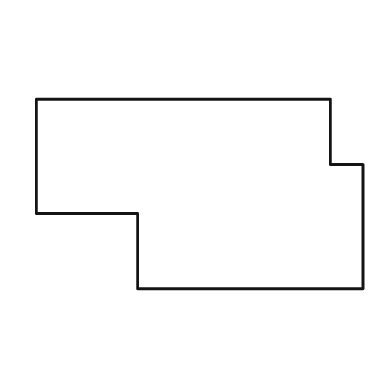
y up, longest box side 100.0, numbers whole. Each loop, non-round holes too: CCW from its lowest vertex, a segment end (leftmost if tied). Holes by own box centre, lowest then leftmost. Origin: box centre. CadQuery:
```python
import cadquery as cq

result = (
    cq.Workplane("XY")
    .moveTo(-19.0, -29.0)
    .lineTo(50.0, -29.0)
    .lineTo(50.0, 9.0)
    .lineTo(40.0, 9.0)
    .lineTo(40.0, 29.0)
    .lineTo(-50.0, 29.0)
    .lineTo(-50.0, -6.0)
    .lineTo(-19.0, -6.0)
    .close()
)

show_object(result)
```